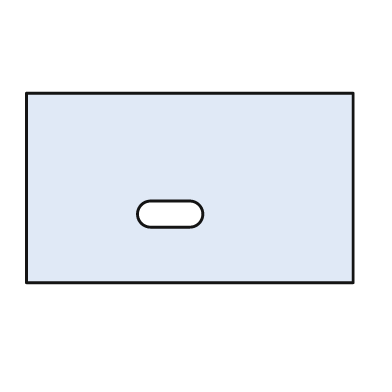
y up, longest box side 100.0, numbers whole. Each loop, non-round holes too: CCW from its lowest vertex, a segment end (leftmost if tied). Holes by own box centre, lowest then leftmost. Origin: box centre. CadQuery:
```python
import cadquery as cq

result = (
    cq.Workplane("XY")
    .moveTo(-50.0, -29.0)
    .lineTo(50.0, -29.0)
    .lineTo(50.0, 29.0)
    .lineTo(-50.0, 29.0)
    .close()
    .moveTo(-12.0, -12.0)
    .lineTo(0.0, -12.0)
    .threePointArc((4.0, -8.0), (0.0, -4.0))
    .lineTo(-12.0, -4.0)
    .threePointArc((-16.0, -8.0), (-12.0, -12.0))
    .close()
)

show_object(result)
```